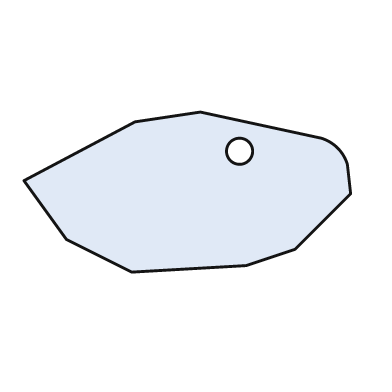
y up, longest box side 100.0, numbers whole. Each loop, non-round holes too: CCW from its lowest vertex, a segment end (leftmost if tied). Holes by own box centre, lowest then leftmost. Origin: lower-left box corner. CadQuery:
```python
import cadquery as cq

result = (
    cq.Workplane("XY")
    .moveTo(33.0, 0.0)
    .lineTo(68.0, 2.0)
    .lineTo(83.0, 7.0)
    .lineTo(100.0, 24.0)
    .lineTo(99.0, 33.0)
    .threePointArc((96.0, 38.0), (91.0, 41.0))
    .lineTo(54.0, 49.0)
    .lineTo(34.0, 46.0)
    .lineTo(0.0, 28.0)
    .lineTo(13.0, 10.0)
    .close()
    .moveTo(66.0, 37.0)
    .circle(4.0)
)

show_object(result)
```